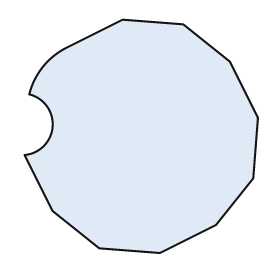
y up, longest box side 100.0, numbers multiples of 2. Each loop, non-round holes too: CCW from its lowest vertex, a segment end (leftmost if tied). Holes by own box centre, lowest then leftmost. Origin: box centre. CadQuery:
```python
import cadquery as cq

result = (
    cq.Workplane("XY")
    .moveTo(8.0, -50.0)
    .lineTo(32.0, -38.0)
    .lineTo(48.0, -18.0)
    .lineTo(50.0, 8.0)
    .lineTo(38.0, 32.0)
    .lineTo(18.0, 48.0)
    .lineTo(-8.0, 50.0)
    .lineTo(-32.0, 38.0)
    .threePointArc((-42.0, 30.0), (-48.0, 18.0))
    .threePointArc((-38.0, 4.0), (-50.0, -8.0))
    .lineTo(-38.0, -32.0)
    .lineTo(-18.0, -48.0)
    .close()
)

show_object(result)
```